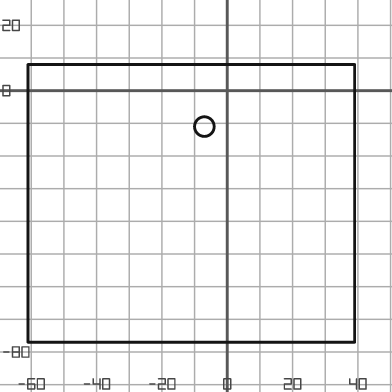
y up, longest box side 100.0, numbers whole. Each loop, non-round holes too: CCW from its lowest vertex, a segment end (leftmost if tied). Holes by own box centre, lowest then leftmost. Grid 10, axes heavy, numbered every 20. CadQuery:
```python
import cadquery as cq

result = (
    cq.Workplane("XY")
    .moveTo(-61.0, -77.0)
    .lineTo(39.0, -77.0)
    .lineTo(39.0, 8.0)
    .lineTo(-61.0, 8.0)
    .close()
    .moveTo(-7.0, -11.0)
    .circle(3.0)
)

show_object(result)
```